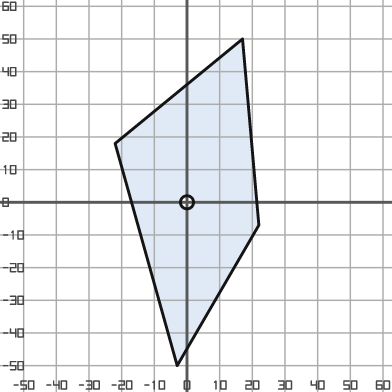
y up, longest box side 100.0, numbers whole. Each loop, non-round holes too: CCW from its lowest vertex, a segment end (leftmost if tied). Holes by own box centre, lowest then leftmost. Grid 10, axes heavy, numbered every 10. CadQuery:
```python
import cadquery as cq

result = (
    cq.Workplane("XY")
    .moveTo(-3.0, -50.0)
    .lineTo(22.0, -7.0)
    .lineTo(17.0, 50.0)
    .lineTo(-22.0, 18.0)
    .close()
    .moveTo(0.0, 0.0)
    .circle(2.0)
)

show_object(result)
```